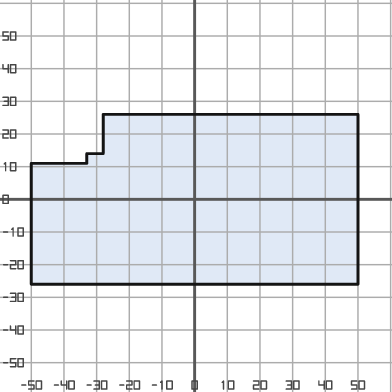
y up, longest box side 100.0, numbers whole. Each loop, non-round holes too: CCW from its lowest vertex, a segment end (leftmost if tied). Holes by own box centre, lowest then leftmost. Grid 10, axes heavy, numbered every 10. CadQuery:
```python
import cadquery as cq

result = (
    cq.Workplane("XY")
    .moveTo(-50.0, -26.0)
    .lineTo(50.0, -26.0)
    .lineTo(50.0, 26.0)
    .lineTo(-28.0, 26.0)
    .lineTo(-28.0, 14.0)
    .lineTo(-33.0, 14.0)
    .lineTo(-33.0, 11.0)
    .lineTo(-50.0, 11.0)
    .close()
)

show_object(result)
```